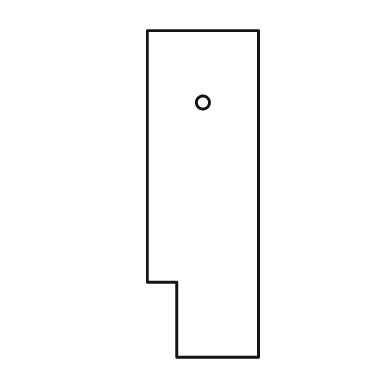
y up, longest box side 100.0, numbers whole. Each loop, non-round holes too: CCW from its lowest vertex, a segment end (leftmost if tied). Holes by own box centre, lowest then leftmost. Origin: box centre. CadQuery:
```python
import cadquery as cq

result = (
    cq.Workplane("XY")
    .moveTo(-8.0, -50.0)
    .lineTo(17.0, -50.0)
    .lineTo(17.0, 50.0)
    .lineTo(-17.0, 50.0)
    .lineTo(-17.0, -27.0)
    .lineTo(-8.0, -27.0)
    .close()
    .moveTo(0.0, 28.0)
    .circle(2.0)
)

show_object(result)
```